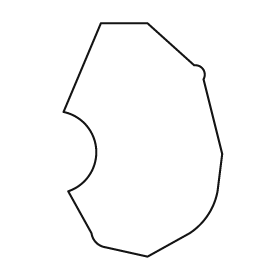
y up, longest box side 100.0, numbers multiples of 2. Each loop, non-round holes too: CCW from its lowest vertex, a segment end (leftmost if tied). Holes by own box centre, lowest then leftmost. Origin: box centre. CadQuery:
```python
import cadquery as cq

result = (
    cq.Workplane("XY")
    .moveTo(2.0, -50.0)
    .lineTo(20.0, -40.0)
    .threePointArc((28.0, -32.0), (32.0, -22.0))
    .lineTo(34.0, -6.0)
    .lineTo(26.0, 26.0)
    .threePointArc((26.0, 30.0), (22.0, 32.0))
    .lineTo(2.0, 50.0)
    .lineTo(-18.0, 50.0)
    .lineTo(-34.0, 12.0)
    .threePointArc((-20.0, -4.0), (-32.0, -22.0))
    .lineTo(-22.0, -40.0)
    .threePointArc((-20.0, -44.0), (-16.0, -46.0))
    .close()
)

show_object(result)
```